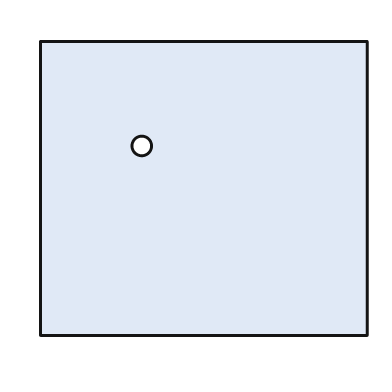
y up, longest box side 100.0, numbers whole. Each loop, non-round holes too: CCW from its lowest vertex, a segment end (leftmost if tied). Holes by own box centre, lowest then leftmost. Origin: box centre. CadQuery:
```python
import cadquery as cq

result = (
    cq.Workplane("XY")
    .moveTo(-50.0, -45.0)
    .lineTo(50.0, -45.0)
    .lineTo(50.0, 45.0)
    .lineTo(-50.0, 45.0)
    .close()
    .moveTo(-19.0, 13.0)
    .circle(3.0)
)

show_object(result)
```